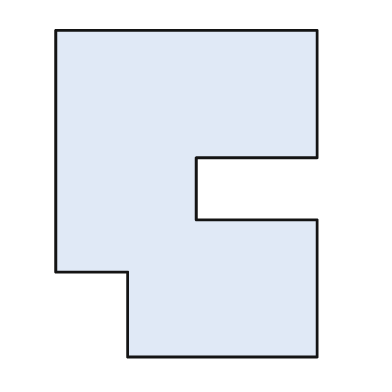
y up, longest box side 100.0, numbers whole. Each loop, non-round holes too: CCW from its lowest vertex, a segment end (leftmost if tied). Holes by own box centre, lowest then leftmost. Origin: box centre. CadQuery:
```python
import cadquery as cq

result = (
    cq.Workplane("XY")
    .moveTo(-18.0, -50.0)
    .lineTo(40.0, -50.0)
    .lineTo(40.0, -8.0)
    .lineTo(3.0, -8.0)
    .lineTo(3.0, 11.0)
    .lineTo(40.0, 11.0)
    .lineTo(40.0, 50.0)
    .lineTo(-40.0, 50.0)
    .lineTo(-40.0, -24.0)
    .lineTo(-18.0, -24.0)
    .close()
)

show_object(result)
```